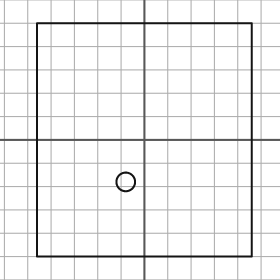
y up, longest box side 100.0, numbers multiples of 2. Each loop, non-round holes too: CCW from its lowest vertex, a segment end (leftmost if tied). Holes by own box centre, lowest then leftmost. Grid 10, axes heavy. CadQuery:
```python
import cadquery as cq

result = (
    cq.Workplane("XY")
    .moveTo(-46.0, -50.0)
    .lineTo(46.0, -50.0)
    .lineTo(46.0, 50.0)
    .lineTo(-46.0, 50.0)
    .close()
    .moveTo(-8.0, -18.0)
    .circle(4.0)
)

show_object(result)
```